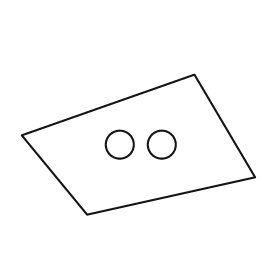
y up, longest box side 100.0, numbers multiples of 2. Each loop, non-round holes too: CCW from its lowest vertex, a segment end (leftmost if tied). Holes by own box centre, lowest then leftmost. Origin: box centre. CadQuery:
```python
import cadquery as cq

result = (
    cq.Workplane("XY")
    .moveTo(-22.0, -30.0)
    .lineTo(50.0, -14.0)
    .lineTo(24.0, 30.0)
    .lineTo(-50.0, 4.0)
    .close()
    .moveTo(-8.0, 0.0)
    .circle(6.0)
    .moveTo(10.0, 0.0)
    .circle(6.0)
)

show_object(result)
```